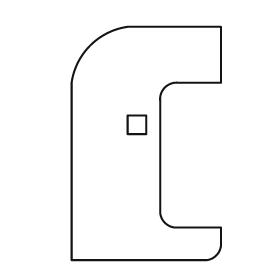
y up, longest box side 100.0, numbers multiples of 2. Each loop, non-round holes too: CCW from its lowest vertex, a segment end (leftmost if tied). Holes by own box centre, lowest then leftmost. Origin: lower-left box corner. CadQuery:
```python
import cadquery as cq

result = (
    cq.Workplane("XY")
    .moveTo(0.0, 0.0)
    .lineTo(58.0, 0.0)
    .threePointArc((62.0, 2.0), (64.0, 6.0))
    .lineTo(64.0, 14.0)
    .lineTo(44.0, 14.0)
    .threePointArc((40.0, 16.0), (38.0, 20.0))
    .lineTo(38.0, 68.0)
    .threePointArc((40.0, 74.0), (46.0, 76.0))
    .lineTo(64.0, 76.0)
    .lineTo(64.0, 100.0)
    .lineTo(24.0, 100.0)
    .threePointArc((8.0, 92.0), (0.0, 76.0))
    .close()
    .moveTo(24.0, 54.0)
    .lineTo(32.0, 54.0)
    .lineTo(32.0, 62.0)
    .lineTo(24.0, 62.0)
    .close()
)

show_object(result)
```